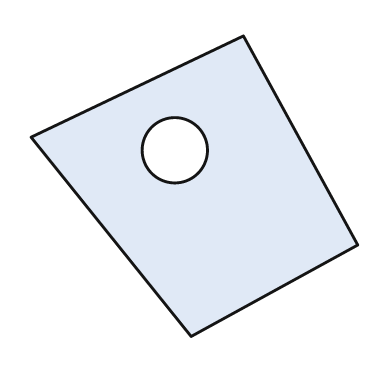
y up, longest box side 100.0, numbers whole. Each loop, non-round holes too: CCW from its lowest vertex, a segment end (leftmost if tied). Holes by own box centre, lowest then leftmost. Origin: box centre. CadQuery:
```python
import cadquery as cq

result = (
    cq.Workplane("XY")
    .moveTo(-1.0, -46.0)
    .lineTo(50.0, -18.0)
    .lineTo(15.0, 46.0)
    .lineTo(-50.0, 15.0)
    .close()
    .moveTo(-6.0, 11.0)
    .circle(10.0)
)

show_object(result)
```